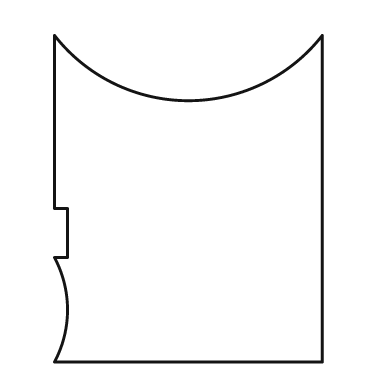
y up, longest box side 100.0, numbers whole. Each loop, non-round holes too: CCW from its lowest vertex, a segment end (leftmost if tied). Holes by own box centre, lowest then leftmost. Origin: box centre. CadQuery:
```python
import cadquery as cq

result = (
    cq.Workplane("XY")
    .moveTo(-41.0, -50.0)
    .lineTo(41.0, -50.0)
    .lineTo(41.0, 50.0)
    .threePointArc((0.0, 30.0), (-41.0, 50.0))
    .lineTo(-41.0, -3.0)
    .lineTo(-37.0, -3.0)
    .lineTo(-37.0, -18.0)
    .lineTo(-41.0, -18.0)
    .threePointArc((-37.0, -34.0), (-41.0, -50.0))
    .close()
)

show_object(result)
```